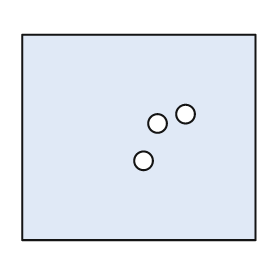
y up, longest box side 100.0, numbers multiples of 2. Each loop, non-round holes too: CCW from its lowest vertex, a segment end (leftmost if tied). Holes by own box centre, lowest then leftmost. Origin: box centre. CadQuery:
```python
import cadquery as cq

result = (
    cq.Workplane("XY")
    .moveTo(-50.0, -44.0)
    .lineTo(50.0, -44.0)
    .lineTo(50.0, 44.0)
    .lineTo(-50.0, 44.0)
    .close()
    .moveTo(2.0, -10.0)
    .circle(4.0)
    .moveTo(8.0, 6.0)
    .circle(4.0)
    .moveTo(20.0, 10.0)
    .circle(4.0)
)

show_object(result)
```